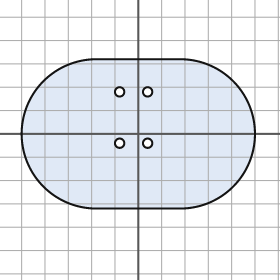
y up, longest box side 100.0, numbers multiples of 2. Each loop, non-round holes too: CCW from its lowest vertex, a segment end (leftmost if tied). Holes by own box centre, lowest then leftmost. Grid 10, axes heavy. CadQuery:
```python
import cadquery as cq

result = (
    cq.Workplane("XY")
    .moveTo(-18.0, -32.0)
    .lineTo(18.0, -32.0)
    .threePointArc((50.0, 0.0), (18.0, 32.0))
    .lineTo(-18.0, 32.0)
    .threePointArc((-50.0, 0.0), (-18.0, -32.0))
    .close()
    .moveTo(-8.0, -4.0)
    .circle(2.0)
    .moveTo(4.0, -4.0)
    .circle(2.0)
    .moveTo(-8.0, 18.0)
    .circle(2.0)
    .moveTo(4.0, 18.0)
    .circle(2.0)
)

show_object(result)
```